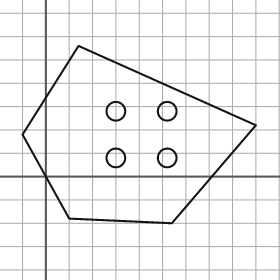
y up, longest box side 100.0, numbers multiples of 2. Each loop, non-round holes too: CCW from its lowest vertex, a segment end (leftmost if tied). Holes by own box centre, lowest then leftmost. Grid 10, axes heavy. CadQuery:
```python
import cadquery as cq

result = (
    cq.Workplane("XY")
    .moveTo(54.0, -20.0)
    .lineTo(90.0, 22.0)
    .lineTo(14.0, 56.0)
    .lineTo(-10.0, 18.0)
    .lineTo(10.0, -18.0)
    .close()
    .moveTo(30.0, 8.0)
    .circle(4.0)
    .moveTo(52.0, 8.0)
    .circle(4.0)
    .moveTo(30.0, 28.0)
    .circle(4.0)
    .moveTo(52.0, 28.0)
    .circle(4.0)
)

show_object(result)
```